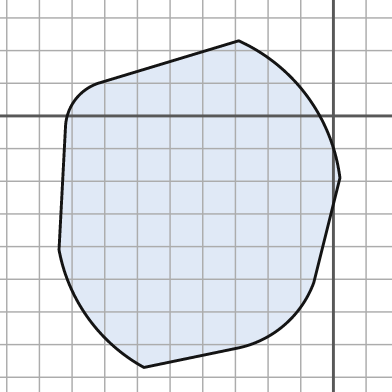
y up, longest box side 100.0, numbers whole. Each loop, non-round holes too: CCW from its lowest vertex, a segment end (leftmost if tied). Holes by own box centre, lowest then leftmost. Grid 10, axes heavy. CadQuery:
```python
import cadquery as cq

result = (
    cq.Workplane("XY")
    .moveTo(-58.0, -77.0)
    .lineTo(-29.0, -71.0)
    .threePointArc((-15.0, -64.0), (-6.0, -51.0))
    .lineTo(2.0, -19.0)
    .threePointArc((-8.0, 6.0), (-29.0, 23.0))
    .lineTo(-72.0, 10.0)
    .threePointArc((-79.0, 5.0), (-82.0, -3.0))
    .lineTo(-84.0, -41.0)
    .threePointArc((-75.0, -62.0), (-58.0, -77.0))
    .close()
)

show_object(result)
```